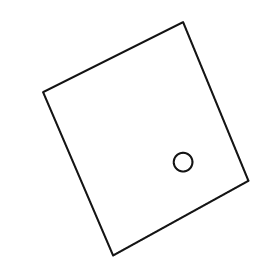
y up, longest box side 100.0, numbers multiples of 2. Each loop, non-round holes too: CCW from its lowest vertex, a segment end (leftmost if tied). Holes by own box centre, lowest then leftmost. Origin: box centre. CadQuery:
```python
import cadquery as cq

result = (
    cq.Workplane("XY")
    .moveTo(-14.0, -50.0)
    .lineTo(44.0, -18.0)
    .lineTo(16.0, 50.0)
    .lineTo(-44.0, 20.0)
    .close()
    .moveTo(16.0, -10.0)
    .circle(4.0)
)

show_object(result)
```